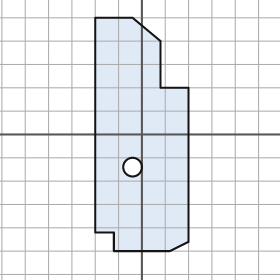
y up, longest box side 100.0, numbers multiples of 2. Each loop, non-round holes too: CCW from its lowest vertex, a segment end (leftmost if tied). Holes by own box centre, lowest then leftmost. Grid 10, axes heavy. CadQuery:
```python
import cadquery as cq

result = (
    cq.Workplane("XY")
    .moveTo(-12.0, -50.0)
    .lineTo(12.0, -50.0)
    .lineTo(20.0, -46.0)
    .lineTo(20.0, 20.0)
    .lineTo(8.0, 20.0)
    .lineTo(8.0, 40.0)
    .lineTo(-4.0, 50.0)
    .lineTo(-20.0, 50.0)
    .lineTo(-20.0, -42.0)
    .lineTo(-12.0, -42.0)
    .close()
    .moveTo(-4.0, -14.0)
    .circle(4.0)
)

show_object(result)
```